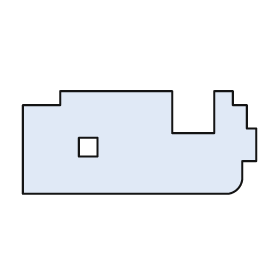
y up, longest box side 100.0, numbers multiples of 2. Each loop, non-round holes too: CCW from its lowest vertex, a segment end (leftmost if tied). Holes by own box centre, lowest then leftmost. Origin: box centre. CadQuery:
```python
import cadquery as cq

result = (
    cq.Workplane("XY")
    .moveTo(-50.0, -22.0)
    .lineTo(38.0, -22.0)
    .threePointArc((42.0, -20.0), (44.0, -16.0))
    .lineTo(44.0, -8.0)
    .lineTo(50.0, -8.0)
    .lineTo(50.0, 6.0)
    .lineTo(46.0, 6.0)
    .lineTo(46.0, 16.0)
    .lineTo(40.0, 16.0)
    .lineTo(40.0, 22.0)
    .lineTo(32.0, 22.0)
    .lineTo(32.0, 4.0)
    .lineTo(14.0, 4.0)
    .lineTo(14.0, 22.0)
    .lineTo(-34.0, 22.0)
    .lineTo(-34.0, 16.0)
    .lineTo(-50.0, 16.0)
    .close()
    .moveTo(-26.0, -6.0)
    .lineTo(-18.0, -6.0)
    .lineTo(-18.0, 2.0)
    .lineTo(-26.0, 2.0)
    .close()
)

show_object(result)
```